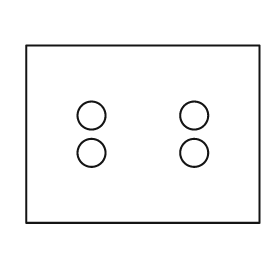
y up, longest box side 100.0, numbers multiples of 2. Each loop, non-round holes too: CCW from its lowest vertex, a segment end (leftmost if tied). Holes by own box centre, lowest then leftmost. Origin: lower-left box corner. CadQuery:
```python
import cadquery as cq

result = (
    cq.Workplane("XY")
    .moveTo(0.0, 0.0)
    .lineTo(100.0, 0.0)
    .lineTo(100.0, 76.0)
    .lineTo(0.0, 76.0)
    .close()
    .moveTo(28.0, 30.0)
    .circle(6.0)
    .moveTo(72.0, 30.0)
    .circle(6.0)
    .moveTo(28.0, 46.0)
    .circle(6.0)
    .moveTo(72.0, 46.0)
    .circle(6.0)
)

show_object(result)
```